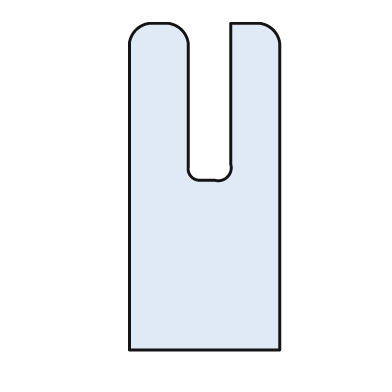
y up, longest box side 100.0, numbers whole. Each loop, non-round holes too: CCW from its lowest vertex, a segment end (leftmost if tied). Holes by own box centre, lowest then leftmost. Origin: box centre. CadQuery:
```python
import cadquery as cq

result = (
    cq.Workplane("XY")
    .moveTo(-23.0, -50.0)
    .lineTo(23.0, -50.0)
    .lineTo(23.0, 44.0)
    .threePointArc((21.0, 48.0), (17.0, 50.0))
    .lineTo(8.0, 50.0)
    .lineTo(8.0, 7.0)
    .threePointArc((7.0, 3.0), (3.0, 2.0))
    .lineTo(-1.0, 2.0)
    .threePointArc((-4.0, 3.0), (-5.0, 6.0))
    .lineTo(-5.0, 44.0)
    .threePointArc((-7.0, 48.0), (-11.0, 50.0))
    .lineTo(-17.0, 50.0)
    .threePointArc((-21.0, 48.0), (-23.0, 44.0))
    .close()
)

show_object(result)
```